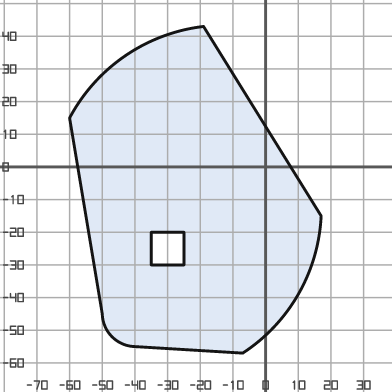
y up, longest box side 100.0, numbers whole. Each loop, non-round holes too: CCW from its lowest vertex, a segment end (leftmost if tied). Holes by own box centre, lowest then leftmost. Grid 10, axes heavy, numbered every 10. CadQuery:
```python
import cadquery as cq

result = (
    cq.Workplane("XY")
    .moveTo(-7.0, -57.0)
    .threePointArc((10.0, -39.0), (17.0, -15.0))
    .lineTo(-19.0, 43.0)
    .threePointArc((-43.0, 34.0), (-60.0, 15.0))
    .lineTo(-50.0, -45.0)
    .threePointArc((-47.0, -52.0), (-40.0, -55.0))
    .close()
    .moveTo(-35.0, -30.0)
    .lineTo(-25.0, -30.0)
    .lineTo(-25.0, -20.0)
    .lineTo(-35.0, -20.0)
    .close()
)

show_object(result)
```